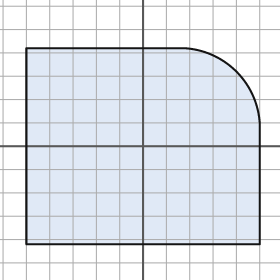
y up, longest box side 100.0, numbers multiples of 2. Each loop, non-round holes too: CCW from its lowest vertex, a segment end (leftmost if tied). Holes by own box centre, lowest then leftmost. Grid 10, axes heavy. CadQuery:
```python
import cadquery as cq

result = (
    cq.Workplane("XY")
    .moveTo(-50.0, -42.0)
    .lineTo(50.0, -42.0)
    .lineTo(50.0, 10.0)
    .threePointArc((40.0, 32.0), (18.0, 42.0))
    .lineTo(-50.0, 42.0)
    .close()
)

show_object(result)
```